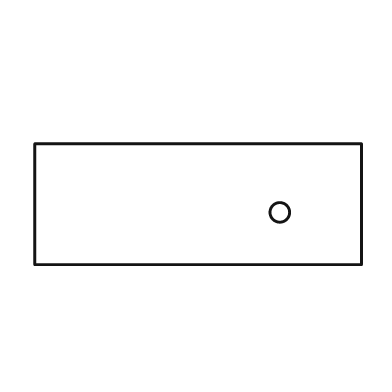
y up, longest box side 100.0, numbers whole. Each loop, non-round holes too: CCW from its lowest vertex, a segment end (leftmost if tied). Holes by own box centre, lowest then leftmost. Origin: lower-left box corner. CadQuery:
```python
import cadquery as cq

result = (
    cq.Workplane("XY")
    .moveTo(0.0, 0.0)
    .lineTo(100.0, 0.0)
    .lineTo(100.0, 37.0)
    .lineTo(0.0, 37.0)
    .close()
    .moveTo(75.0, 16.0)
    .circle(3.0)
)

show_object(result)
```